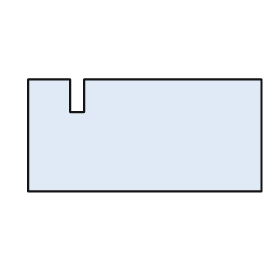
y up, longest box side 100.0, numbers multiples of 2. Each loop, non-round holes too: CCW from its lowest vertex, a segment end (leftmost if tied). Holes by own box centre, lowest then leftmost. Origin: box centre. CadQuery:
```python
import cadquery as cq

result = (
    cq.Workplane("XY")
    .moveTo(-50.0, -24.0)
    .lineTo(50.0, -24.0)
    .lineTo(50.0, 24.0)
    .lineTo(-26.0, 24.0)
    .lineTo(-26.0, 10.0)
    .lineTo(-32.0, 10.0)
    .lineTo(-32.0, 24.0)
    .lineTo(-50.0, 24.0)
    .close()
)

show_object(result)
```